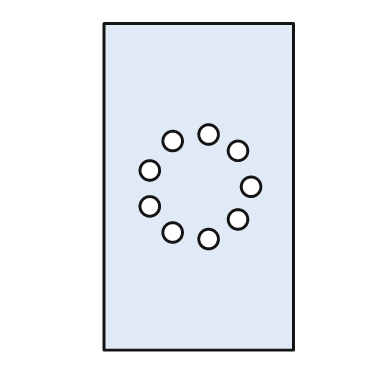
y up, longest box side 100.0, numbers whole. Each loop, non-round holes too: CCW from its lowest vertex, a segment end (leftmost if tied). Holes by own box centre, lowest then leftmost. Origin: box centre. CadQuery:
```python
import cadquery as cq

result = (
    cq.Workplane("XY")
    .moveTo(-29.0, -50.0)
    .lineTo(29.0, -50.0)
    .lineTo(29.0, 50.0)
    .lineTo(-29.0, 50.0)
    .close()
    .moveTo(3.0, -16.0)
    .circle(3.0)
    .moveTo(-8.0, -14.0)
    .circle(3.0)
    .moveTo(12.0, -10.0)
    .circle(3.0)
    .moveTo(-15.0, -6.0)
    .circle(3.0)
    .moveTo(16.0, 0.0)
    .circle(3.0)
    .moveTo(-15.0, 5.0)
    .circle(3.0)
    .moveTo(12.0, 11.0)
    .circle(3.0)
    .moveTo(-8.0, 14.0)
    .circle(3.0)
    .moveTo(3.0, 16.0)
    .circle(3.0)
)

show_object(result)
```